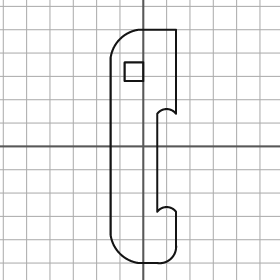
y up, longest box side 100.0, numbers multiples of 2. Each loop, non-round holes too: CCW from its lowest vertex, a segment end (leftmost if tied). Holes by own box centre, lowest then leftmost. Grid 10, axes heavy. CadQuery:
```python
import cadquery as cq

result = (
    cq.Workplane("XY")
    .moveTo(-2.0, -50.0)
    .lineTo(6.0, -50.0)
    .threePointArc((12.0, -48.0), (14.0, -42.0))
    .lineTo(14.0, -28.0)
    .threePointArc((10.0, -26.0), (6.0, -28.0))
    .lineTo(6.0, 14.0)
    .threePointArc((10.0, 16.0), (14.0, 14.0))
    .lineTo(14.0, 50.0)
    .lineTo(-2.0, 50.0)
    .threePointArc((-10.0, 46.0), (-14.0, 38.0))
    .lineTo(-14.0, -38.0)
    .threePointArc((-10.0, -46.0), (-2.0, -50.0))
    .close()
    .moveTo(-8.0, 28.0)
    .lineTo(0.0, 28.0)
    .lineTo(0.0, 36.0)
    .lineTo(-8.0, 36.0)
    .close()
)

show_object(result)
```